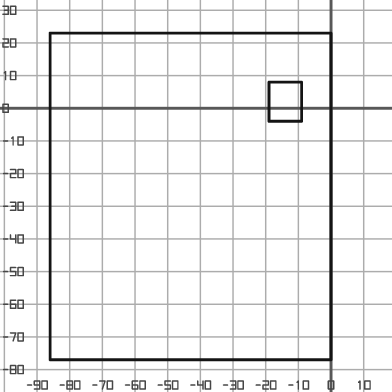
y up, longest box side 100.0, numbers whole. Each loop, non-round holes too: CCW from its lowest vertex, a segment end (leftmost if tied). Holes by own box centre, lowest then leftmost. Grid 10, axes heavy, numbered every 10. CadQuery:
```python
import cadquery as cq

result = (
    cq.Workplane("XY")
    .moveTo(-86.0, -77.0)
    .lineTo(0.0, -77.0)
    .lineTo(0.0, 23.0)
    .lineTo(-86.0, 23.0)
    .close()
    .moveTo(-19.0, -4.0)
    .lineTo(-9.0, -4.0)
    .lineTo(-9.0, 8.0)
    .lineTo(-19.0, 8.0)
    .close()
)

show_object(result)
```